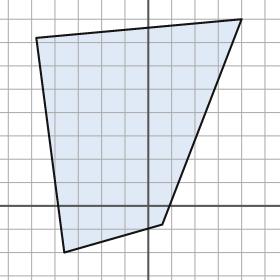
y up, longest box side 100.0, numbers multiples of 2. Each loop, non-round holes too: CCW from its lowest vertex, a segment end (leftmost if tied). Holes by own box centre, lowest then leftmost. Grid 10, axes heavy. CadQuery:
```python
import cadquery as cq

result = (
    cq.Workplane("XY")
    .moveTo(-36.0, -20.0)
    .lineTo(6.0, -8.0)
    .lineTo(40.0, 80.0)
    .lineTo(-48.0, 72.0)
    .close()
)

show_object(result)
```